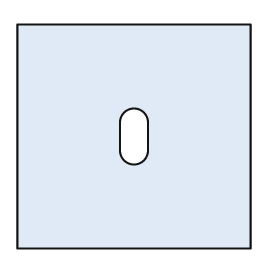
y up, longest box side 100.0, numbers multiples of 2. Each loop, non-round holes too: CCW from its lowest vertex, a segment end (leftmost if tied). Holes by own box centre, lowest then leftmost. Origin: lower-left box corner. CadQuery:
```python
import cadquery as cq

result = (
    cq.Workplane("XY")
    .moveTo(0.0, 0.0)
    .lineTo(100.0, 0.0)
    .lineTo(100.0, 96.0)
    .lineTo(0.0, 96.0)
    .close()
    .moveTo(44.0, 42.0)
    .threePointArc((50.0, 36.0), (56.0, 42.0))
    .lineTo(56.0, 54.0)
    .threePointArc((50.0, 60.0), (44.0, 54.0))
    .close()
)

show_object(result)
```